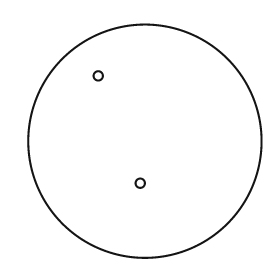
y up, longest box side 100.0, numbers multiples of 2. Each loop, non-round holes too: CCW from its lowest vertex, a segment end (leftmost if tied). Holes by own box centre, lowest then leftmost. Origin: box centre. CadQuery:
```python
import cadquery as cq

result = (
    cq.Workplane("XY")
    .moveTo(0.0, 0.0)
    .circle(50.0)
    .moveTo(-2.0, -18.0)
    .circle(2.0)
    .moveTo(-20.0, 28.0)
    .circle(2.0)
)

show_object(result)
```